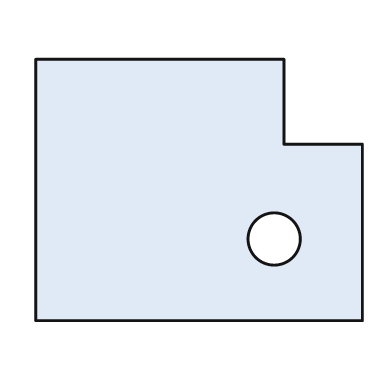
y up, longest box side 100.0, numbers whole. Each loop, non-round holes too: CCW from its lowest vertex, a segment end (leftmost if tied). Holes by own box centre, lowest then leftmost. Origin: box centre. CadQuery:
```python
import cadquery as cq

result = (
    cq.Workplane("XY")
    .moveTo(-50.0, -40.0)
    .lineTo(50.0, -40.0)
    .lineTo(50.0, 14.0)
    .lineTo(26.0, 14.0)
    .lineTo(26.0, 40.0)
    .lineTo(-50.0, 40.0)
    .close()
    .moveTo(23.0, -15.0)
    .circle(8.0)
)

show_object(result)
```